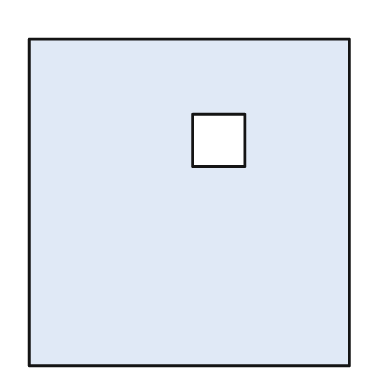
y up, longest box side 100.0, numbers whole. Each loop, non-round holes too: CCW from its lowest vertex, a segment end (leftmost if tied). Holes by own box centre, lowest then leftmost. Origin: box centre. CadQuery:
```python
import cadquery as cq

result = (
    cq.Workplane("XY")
    .moveTo(-49.0, -50.0)
    .lineTo(49.0, -50.0)
    .lineTo(49.0, 50.0)
    .lineTo(-49.0, 50.0)
    .close()
    .moveTo(1.0, 11.0)
    .lineTo(17.0, 11.0)
    .lineTo(17.0, 27.0)
    .lineTo(1.0, 27.0)
    .close()
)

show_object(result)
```